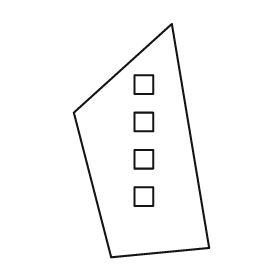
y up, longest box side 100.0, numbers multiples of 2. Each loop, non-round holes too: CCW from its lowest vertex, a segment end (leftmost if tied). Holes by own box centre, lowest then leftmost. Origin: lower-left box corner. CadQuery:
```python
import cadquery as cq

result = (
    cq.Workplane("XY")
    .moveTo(16.0, 0.0)
    .lineTo(58.0, 4.0)
    .lineTo(42.0, 100.0)
    .lineTo(0.0, 62.0)
    .close()
    .moveTo(26.0, 22.0)
    .lineTo(34.0, 22.0)
    .lineTo(34.0, 30.0)
    .lineTo(26.0, 30.0)
    .close()
    .moveTo(26.0, 38.0)
    .lineTo(34.0, 38.0)
    .lineTo(34.0, 46.0)
    .lineTo(26.0, 46.0)
    .close()
    .moveTo(26.0, 54.0)
    .lineTo(34.0, 54.0)
    .lineTo(34.0, 62.0)
    .lineTo(26.0, 62.0)
    .close()
    .moveTo(26.0, 70.0)
    .lineTo(34.0, 70.0)
    .lineTo(34.0, 78.0)
    .lineTo(26.0, 78.0)
    .close()
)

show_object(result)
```